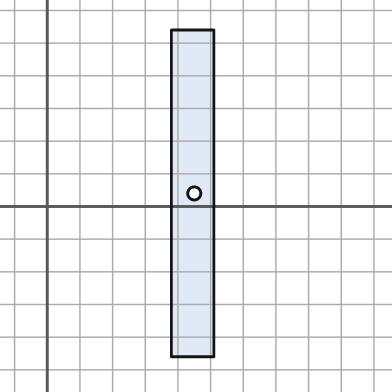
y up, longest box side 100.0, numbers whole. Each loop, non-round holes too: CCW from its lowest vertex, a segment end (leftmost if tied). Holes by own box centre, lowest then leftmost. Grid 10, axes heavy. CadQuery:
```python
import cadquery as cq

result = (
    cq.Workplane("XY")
    .moveTo(38.0, -46.0)
    .lineTo(51.0, -46.0)
    .lineTo(51.0, 54.0)
    .lineTo(38.0, 54.0)
    .close()
    .moveTo(45.0, 4.0)
    .circle(2.0)
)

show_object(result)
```